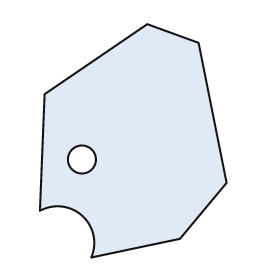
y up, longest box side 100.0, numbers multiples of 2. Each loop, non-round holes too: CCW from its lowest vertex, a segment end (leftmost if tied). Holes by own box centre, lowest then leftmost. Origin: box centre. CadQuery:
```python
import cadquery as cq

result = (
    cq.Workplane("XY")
    .moveTo(-18.0, -50.0)
    .lineTo(20.0, -42.0)
    .lineTo(40.0, -18.0)
    .lineTo(28.0, 42.0)
    .lineTo(6.0, 50.0)
    .lineTo(-38.0, 20.0)
    .lineTo(-40.0, -30.0)
    .threePointArc((-22.0, -32.0), (-18.0, -50.0))
    .close()
    .moveTo(-22.0, -8.0)
    .circle(6.0)
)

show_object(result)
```